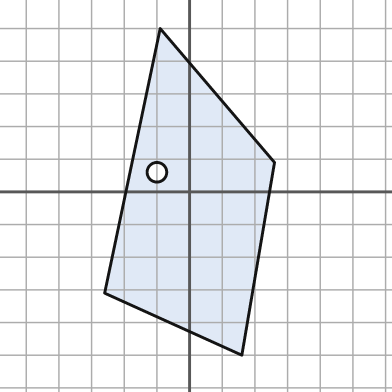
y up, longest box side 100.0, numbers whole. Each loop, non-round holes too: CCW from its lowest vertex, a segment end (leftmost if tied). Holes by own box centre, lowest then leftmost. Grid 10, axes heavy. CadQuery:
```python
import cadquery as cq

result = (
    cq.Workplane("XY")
    .moveTo(16.0, -50.0)
    .lineTo(26.0, 9.0)
    .lineTo(-9.0, 50.0)
    .lineTo(-26.0, -31.0)
    .close()
    .moveTo(-10.0, 6.0)
    .circle(3.0)
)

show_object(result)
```